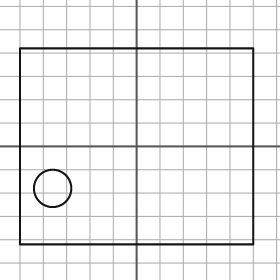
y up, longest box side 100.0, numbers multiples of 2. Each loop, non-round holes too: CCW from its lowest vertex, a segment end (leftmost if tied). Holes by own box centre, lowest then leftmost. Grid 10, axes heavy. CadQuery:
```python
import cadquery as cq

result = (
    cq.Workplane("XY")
    .moveTo(-50.0, -42.0)
    .lineTo(50.0, -42.0)
    .lineTo(50.0, 42.0)
    .lineTo(-50.0, 42.0)
    .close()
    .moveTo(-36.0, -18.0)
    .circle(8.0)
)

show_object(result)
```